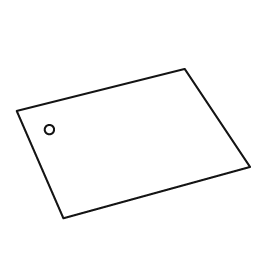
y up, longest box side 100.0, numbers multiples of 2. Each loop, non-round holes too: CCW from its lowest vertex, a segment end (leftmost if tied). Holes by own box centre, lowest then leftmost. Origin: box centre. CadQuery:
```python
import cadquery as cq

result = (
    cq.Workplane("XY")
    .moveTo(-30.0, -32.0)
    .lineTo(50.0, -10.0)
    .lineTo(22.0, 32.0)
    .lineTo(-50.0, 14.0)
    .close()
    .moveTo(-36.0, 6.0)
    .circle(2.0)
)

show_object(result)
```